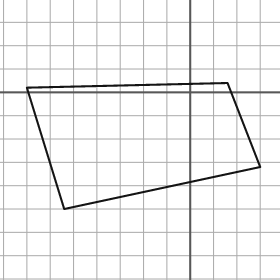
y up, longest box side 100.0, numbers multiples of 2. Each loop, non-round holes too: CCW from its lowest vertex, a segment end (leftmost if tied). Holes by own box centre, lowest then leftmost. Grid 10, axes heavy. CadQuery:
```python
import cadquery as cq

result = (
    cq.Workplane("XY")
    .moveTo(-54.0, -50.0)
    .lineTo(30.0, -32.0)
    .lineTo(16.0, 4.0)
    .lineTo(-70.0, 2.0)
    .close()
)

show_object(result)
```